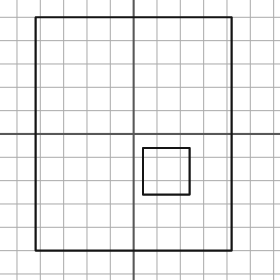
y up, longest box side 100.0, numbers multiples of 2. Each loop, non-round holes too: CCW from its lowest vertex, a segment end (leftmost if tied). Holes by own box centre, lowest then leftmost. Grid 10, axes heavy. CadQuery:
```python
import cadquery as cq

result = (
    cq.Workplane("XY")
    .moveTo(-42.0, -50.0)
    .lineTo(42.0, -50.0)
    .lineTo(42.0, 50.0)
    .lineTo(-42.0, 50.0)
    .close()
    .moveTo(4.0, -26.0)
    .lineTo(24.0, -26.0)
    .lineTo(24.0, -6.0)
    .lineTo(4.0, -6.0)
    .close()
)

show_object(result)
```